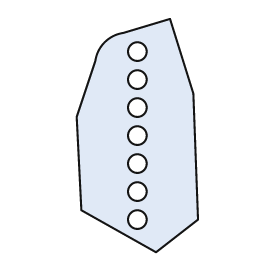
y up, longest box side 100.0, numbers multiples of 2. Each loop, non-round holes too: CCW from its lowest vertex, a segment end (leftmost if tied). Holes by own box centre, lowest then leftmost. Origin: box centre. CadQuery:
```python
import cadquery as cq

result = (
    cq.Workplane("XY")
    .moveTo(8.0, -50.0)
    .lineTo(26.0, -36.0)
    .lineTo(24.0, 18.0)
    .lineTo(14.0, 50.0)
    .lineTo(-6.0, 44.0)
    .threePointArc((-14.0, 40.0), (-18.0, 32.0))
    .lineTo(-26.0, 8.0)
    .lineTo(-24.0, -32.0)
    .close()
    .moveTo(0.0, -36.0)
    .circle(4.0)
    .moveTo(0.0, -24.0)
    .circle(4.0)
    .moveTo(0.0, -12.0)
    .circle(4.0)
    .moveTo(0.0, 0.0)
    .circle(4.0)
    .moveTo(0.0, 12.0)
    .circle(4.0)
    .moveTo(0.0, 24.0)
    .circle(4.0)
    .moveTo(0.0, 36.0)
    .circle(4.0)
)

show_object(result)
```